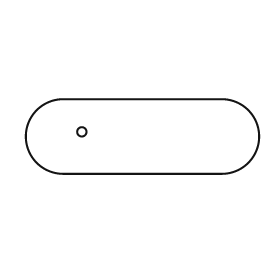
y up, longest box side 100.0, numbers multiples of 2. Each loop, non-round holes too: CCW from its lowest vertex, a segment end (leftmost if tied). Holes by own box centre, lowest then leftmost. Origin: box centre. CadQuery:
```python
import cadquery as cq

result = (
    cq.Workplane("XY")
    .moveTo(-34.0, -16.0)
    .lineTo(34.0, -16.0)
    .threePointArc((50.0, 0.0), (34.0, 16.0))
    .lineTo(-34.0, 16.0)
    .threePointArc((-50.0, 0.0), (-34.0, -16.0))
    .close()
    .moveTo(-26.0, 2.0)
    .circle(2.0)
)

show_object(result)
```